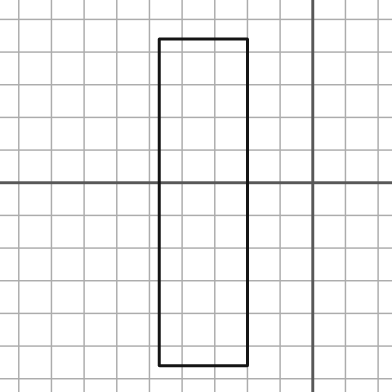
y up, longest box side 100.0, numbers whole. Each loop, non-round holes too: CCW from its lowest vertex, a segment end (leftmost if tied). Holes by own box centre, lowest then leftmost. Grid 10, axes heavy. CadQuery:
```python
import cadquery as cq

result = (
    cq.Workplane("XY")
    .moveTo(-47.0, -56.0)
    .lineTo(-20.0, -56.0)
    .lineTo(-20.0, 44.0)
    .lineTo(-47.0, 44.0)
    .close()
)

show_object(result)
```